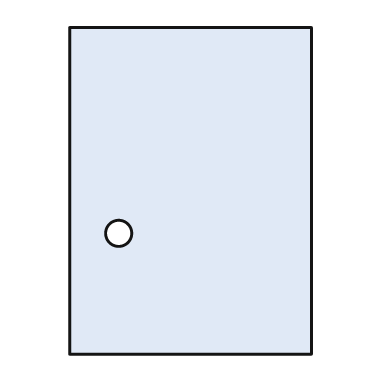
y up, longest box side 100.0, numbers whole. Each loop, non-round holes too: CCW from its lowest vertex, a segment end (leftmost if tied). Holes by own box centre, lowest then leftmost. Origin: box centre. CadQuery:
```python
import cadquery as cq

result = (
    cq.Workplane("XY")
    .moveTo(-37.0, -50.0)
    .lineTo(37.0, -50.0)
    .lineTo(37.0, 50.0)
    .lineTo(-37.0, 50.0)
    .close()
    .moveTo(-22.0, -13.0)
    .circle(4.0)
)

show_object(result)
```